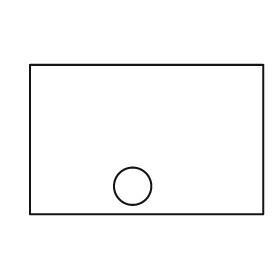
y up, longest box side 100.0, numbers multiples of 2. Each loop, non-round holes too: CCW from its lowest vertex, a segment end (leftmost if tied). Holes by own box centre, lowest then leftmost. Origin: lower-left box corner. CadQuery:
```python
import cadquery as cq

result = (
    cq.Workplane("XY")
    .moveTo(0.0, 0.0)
    .lineTo(100.0, 0.0)
    .lineTo(100.0, 64.0)
    .lineTo(0.0, 64.0)
    .close()
    .moveTo(44.0, 12.0)
    .circle(8.0)
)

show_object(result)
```